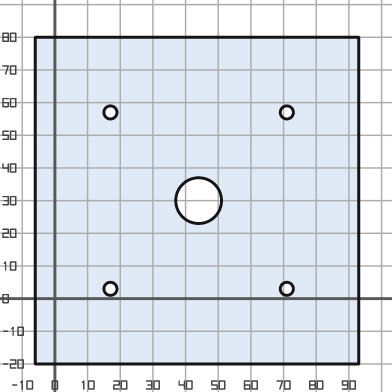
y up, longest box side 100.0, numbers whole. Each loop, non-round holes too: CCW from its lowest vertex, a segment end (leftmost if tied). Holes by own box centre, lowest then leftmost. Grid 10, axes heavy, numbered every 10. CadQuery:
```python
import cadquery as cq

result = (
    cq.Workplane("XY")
    .moveTo(-6.0, -20.0)
    .lineTo(93.0, -20.0)
    .lineTo(93.0, 80.0)
    .lineTo(-6.0, 80.0)
    .close()
    .moveTo(17.0, 3.0)
    .circle(2.0)
    .moveTo(71.0, 3.0)
    .circle(2.0)
    .moveTo(44.0, 30.0)
    .circle(7.0)
    .moveTo(17.0, 57.0)
    .circle(2.0)
    .moveTo(71.0, 57.0)
    .circle(2.0)
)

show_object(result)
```